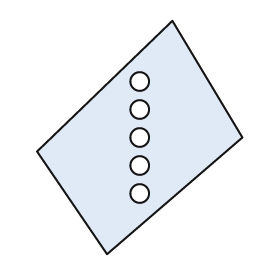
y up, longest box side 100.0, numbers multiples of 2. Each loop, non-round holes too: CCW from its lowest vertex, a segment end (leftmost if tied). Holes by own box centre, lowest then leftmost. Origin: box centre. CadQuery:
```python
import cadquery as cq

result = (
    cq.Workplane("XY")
    .moveTo(-14.0, -50.0)
    .lineTo(44.0, 0.0)
    .lineTo(14.0, 50.0)
    .lineTo(-44.0, -6.0)
    .close()
    .moveTo(0.0, -24.0)
    .circle(4.0)
    .moveTo(0.0, -12.0)
    .circle(4.0)
    .moveTo(0.0, 0.0)
    .circle(4.0)
    .moveTo(0.0, 12.0)
    .circle(4.0)
    .moveTo(0.0, 24.0)
    .circle(4.0)
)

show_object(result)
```